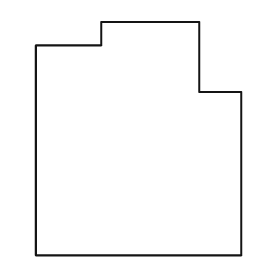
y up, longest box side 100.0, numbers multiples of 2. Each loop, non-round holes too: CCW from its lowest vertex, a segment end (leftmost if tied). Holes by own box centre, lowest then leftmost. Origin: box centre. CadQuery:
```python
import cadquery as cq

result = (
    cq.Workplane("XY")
    .moveTo(-44.0, -50.0)
    .lineTo(44.0, -50.0)
    .lineTo(44.0, 20.0)
    .lineTo(26.0, 20.0)
    .lineTo(26.0, 50.0)
    .lineTo(-16.0, 50.0)
    .lineTo(-16.0, 40.0)
    .lineTo(-44.0, 40.0)
    .close()
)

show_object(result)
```